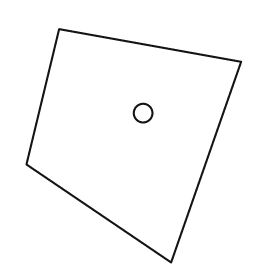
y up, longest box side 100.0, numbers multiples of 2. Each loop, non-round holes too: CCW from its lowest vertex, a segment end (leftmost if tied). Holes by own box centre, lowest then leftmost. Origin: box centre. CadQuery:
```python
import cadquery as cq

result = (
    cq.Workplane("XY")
    .moveTo(16.0, -50.0)
    .lineTo(46.0, 36.0)
    .lineTo(-32.0, 50.0)
    .lineTo(-46.0, -8.0)
    .close()
    .moveTo(4.0, 14.0)
    .circle(4.0)
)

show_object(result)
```